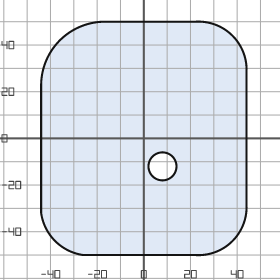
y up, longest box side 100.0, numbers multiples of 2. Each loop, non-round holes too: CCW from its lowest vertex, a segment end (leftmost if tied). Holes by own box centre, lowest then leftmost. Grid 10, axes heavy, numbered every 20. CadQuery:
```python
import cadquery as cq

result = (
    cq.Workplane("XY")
    .moveTo(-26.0, -50.0)
    .lineTo(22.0, -50.0)
    .threePointArc((38.0, -44.0), (44.0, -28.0))
    .lineTo(44.0, 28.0)
    .threePointArc((38.0, 44.0), (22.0, 50.0))
    .lineTo(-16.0, 50.0)
    .threePointArc((-36.0, 42.0), (-44.0, 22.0))
    .lineTo(-44.0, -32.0)
    .threePointArc((-38.0, -44.0), (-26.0, -50.0))
    .close()
    .moveTo(8.0, -12.0)
    .circle(6.0)
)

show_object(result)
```